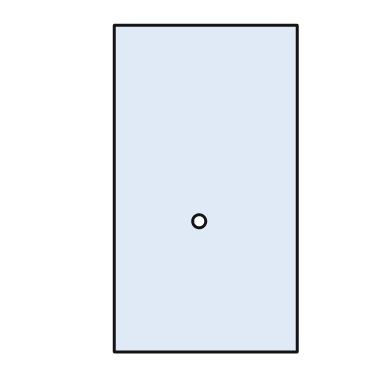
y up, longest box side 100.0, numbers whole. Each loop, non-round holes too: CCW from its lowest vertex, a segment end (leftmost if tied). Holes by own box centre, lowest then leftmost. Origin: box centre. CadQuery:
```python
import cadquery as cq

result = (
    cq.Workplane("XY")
    .moveTo(-28.0, -50.0)
    .lineTo(28.0, -50.0)
    .lineTo(28.0, 50.0)
    .lineTo(-28.0, 50.0)
    .close()
    .moveTo(-2.0, -10.0)
    .circle(2.0)
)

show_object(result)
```